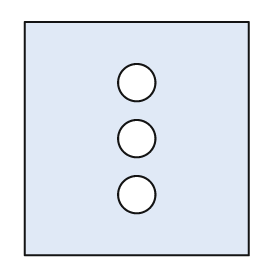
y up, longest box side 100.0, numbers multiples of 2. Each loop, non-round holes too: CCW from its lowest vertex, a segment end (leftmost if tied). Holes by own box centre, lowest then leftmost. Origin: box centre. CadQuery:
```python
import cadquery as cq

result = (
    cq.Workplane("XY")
    .moveTo(-48.0, -50.0)
    .lineTo(48.0, -50.0)
    .lineTo(48.0, 50.0)
    .lineTo(-48.0, 50.0)
    .close()
    .moveTo(0.0, -24.0)
    .circle(8.0)
    .moveTo(0.0, 0.0)
    .circle(8.0)
    .moveTo(0.0, 24.0)
    .circle(8.0)
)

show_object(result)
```